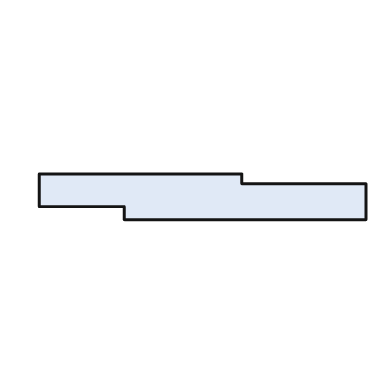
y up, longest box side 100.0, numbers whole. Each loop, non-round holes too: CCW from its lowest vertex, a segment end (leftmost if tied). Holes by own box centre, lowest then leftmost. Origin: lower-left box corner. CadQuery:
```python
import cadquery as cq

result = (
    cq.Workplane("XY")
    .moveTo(26.0, 0.0)
    .lineTo(100.0, 0.0)
    .lineTo(100.0, 11.0)
    .lineTo(62.0, 11.0)
    .lineTo(62.0, 14.0)
    .lineTo(0.0, 14.0)
    .lineTo(0.0, 4.0)
    .lineTo(26.0, 4.0)
    .close()
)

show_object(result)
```